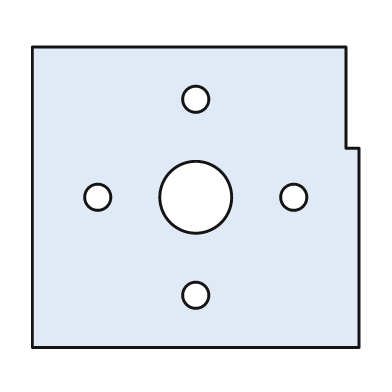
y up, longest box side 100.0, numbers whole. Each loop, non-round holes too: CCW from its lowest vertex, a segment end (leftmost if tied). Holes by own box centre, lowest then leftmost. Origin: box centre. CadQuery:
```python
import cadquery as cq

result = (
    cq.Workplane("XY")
    .moveTo(-50.0, -46.0)
    .lineTo(50.0, -46.0)
    .lineTo(50.0, 15.0)
    .lineTo(46.0, 15.0)
    .lineTo(46.0, 46.0)
    .lineTo(-50.0, 46.0)
    .close()
    .moveTo(0.0, -30.0)
    .circle(4.0)
    .moveTo(-30.0, 0.0)
    .circle(4.0)
    .moveTo(0.0, 0.0)
    .circle(11.0)
    .moveTo(30.0, 0.0)
    .circle(4.0)
    .moveTo(0.0, 30.0)
    .circle(4.0)
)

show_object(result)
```